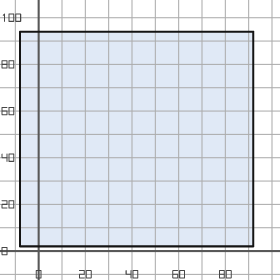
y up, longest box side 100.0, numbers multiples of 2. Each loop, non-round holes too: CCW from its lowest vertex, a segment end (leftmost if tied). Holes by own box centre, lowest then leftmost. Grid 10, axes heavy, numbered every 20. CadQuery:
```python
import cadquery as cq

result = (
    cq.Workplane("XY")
    .moveTo(-8.0, 2.0)
    .lineTo(92.0, 2.0)
    .lineTo(92.0, 94.0)
    .lineTo(-8.0, 94.0)
    .close()
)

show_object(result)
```